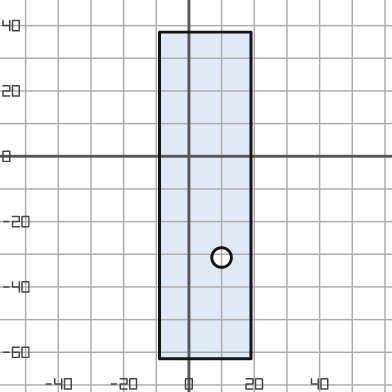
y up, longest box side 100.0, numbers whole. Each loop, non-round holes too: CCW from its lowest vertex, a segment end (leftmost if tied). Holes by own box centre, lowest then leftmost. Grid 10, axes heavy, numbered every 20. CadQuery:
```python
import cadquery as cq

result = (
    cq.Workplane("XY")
    .moveTo(-9.0, -62.0)
    .lineTo(19.0, -62.0)
    .lineTo(19.0, 38.0)
    .lineTo(-9.0, 38.0)
    .close()
    .moveTo(10.0, -31.0)
    .circle(3.0)
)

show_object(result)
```